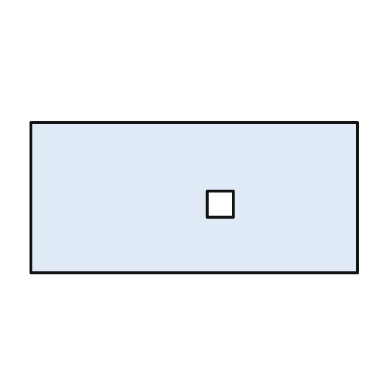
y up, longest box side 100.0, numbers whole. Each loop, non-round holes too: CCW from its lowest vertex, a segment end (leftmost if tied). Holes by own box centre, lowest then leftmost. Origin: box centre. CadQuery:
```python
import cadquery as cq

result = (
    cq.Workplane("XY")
    .moveTo(-50.0, -23.0)
    .lineTo(50.0, -23.0)
    .lineTo(50.0, 23.0)
    .lineTo(-50.0, 23.0)
    .close()
    .moveTo(4.0, -6.0)
    .lineTo(12.0, -6.0)
    .lineTo(12.0, 2.0)
    .lineTo(4.0, 2.0)
    .close()
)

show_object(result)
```